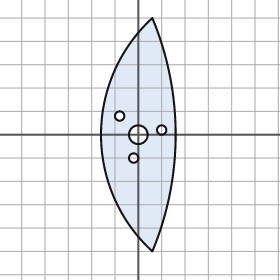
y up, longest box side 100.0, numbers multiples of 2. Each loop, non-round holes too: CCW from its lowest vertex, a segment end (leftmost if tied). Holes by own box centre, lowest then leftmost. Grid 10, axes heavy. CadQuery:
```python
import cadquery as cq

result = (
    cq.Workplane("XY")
    .moveTo(6.0, -50.0)
    .threePointArc((16.0, 0.0), (6.0, 50.0))
    .threePointArc((-16.0, 0.0), (6.0, -50.0))
    .close()
    .moveTo(-2.0, -10.0)
    .circle(2.0)
    .moveTo(0.0, 0.0)
    .circle(4.0)
    .moveTo(10.0, 2.0)
    .circle(2.0)
    .moveTo(-8.0, 8.0)
    .circle(2.0)
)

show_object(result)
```